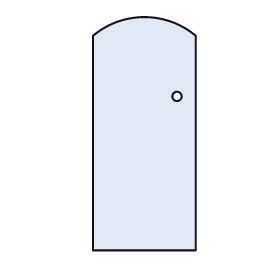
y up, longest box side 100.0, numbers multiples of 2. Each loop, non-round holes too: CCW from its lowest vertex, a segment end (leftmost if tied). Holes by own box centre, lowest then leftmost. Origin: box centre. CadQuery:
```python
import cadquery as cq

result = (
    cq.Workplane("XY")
    .moveTo(-22.0, -50.0)
    .lineTo(22.0, -50.0)
    .lineTo(22.0, 42.0)
    .threePointArc((0.0, 50.0), (-22.0, 42.0))
    .close()
    .moveTo(14.0, 16.0)
    .circle(2.0)
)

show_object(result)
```